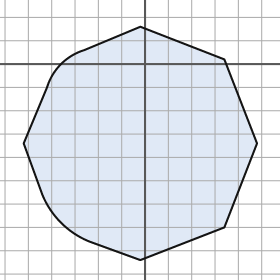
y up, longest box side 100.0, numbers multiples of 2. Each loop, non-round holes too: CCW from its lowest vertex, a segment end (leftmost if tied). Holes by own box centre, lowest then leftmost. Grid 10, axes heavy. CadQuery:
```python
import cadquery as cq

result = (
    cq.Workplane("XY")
    .moveTo(-2.0, -84.0)
    .lineTo(34.0, -70.0)
    .lineTo(48.0, -34.0)
    .lineTo(34.0, 2.0)
    .lineTo(-2.0, 16.0)
    .lineTo(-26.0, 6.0)
    .threePointArc((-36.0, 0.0), (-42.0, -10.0))
    .lineTo(-52.0, -34.0)
    .lineTo(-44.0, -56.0)
    .threePointArc((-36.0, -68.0), (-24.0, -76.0))
    .close()
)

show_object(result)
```